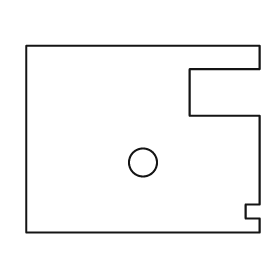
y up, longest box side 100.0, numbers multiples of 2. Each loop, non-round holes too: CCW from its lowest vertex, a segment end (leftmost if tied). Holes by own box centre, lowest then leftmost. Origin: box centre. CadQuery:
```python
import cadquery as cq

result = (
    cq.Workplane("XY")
    .moveTo(-50.0, -40.0)
    .lineTo(50.0, -40.0)
    .lineTo(50.0, -34.0)
    .lineTo(44.0, -34.0)
    .lineTo(44.0, -28.0)
    .lineTo(50.0, -28.0)
    .lineTo(50.0, 10.0)
    .lineTo(20.0, 10.0)
    .lineTo(20.0, 30.0)
    .lineTo(50.0, 30.0)
    .lineTo(50.0, 40.0)
    .lineTo(-50.0, 40.0)
    .close()
    .moveTo(0.0, -10.0)
    .circle(6.0)
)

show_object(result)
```